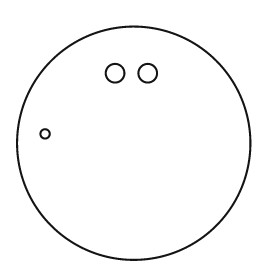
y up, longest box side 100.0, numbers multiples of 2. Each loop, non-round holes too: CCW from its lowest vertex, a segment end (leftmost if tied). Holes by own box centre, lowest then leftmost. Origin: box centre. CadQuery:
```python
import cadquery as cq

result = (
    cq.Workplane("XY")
    .moveTo(0.0, 0.0)
    .circle(50.0)
    .moveTo(-38.0, 4.0)
    .circle(2.0)
    .moveTo(-8.0, 30.0)
    .circle(4.0)
    .moveTo(6.0, 30.0)
    .circle(4.0)
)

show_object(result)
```